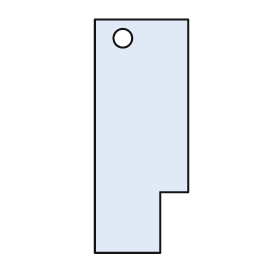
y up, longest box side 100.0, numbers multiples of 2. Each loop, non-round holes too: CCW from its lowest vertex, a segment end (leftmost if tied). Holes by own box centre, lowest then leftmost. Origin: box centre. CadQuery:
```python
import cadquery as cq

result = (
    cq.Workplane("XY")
    .moveTo(-20.0, -50.0)
    .lineTo(8.0, -50.0)
    .lineTo(8.0, -24.0)
    .lineTo(20.0, -24.0)
    .lineTo(20.0, 50.0)
    .lineTo(-20.0, 50.0)
    .close()
    .moveTo(-8.0, 42.0)
    .circle(4.0)
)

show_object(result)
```